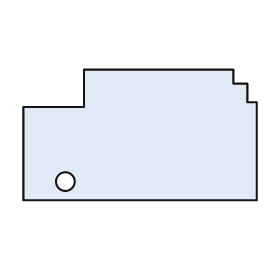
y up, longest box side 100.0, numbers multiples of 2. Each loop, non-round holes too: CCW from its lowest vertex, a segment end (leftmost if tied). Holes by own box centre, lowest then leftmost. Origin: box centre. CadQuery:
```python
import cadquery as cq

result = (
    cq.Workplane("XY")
    .moveTo(-50.0, -28.0)
    .lineTo(50.0, -28.0)
    .lineTo(50.0, 14.0)
    .lineTo(46.0, 14.0)
    .lineTo(46.0, 22.0)
    .lineTo(40.0, 22.0)
    .lineTo(40.0, 28.0)
    .lineTo(-24.0, 28.0)
    .lineTo(-24.0, 12.0)
    .lineTo(-50.0, 12.0)
    .close()
    .moveTo(-32.0, -20.0)
    .circle(4.0)
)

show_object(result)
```